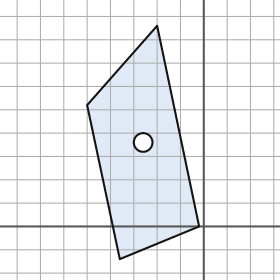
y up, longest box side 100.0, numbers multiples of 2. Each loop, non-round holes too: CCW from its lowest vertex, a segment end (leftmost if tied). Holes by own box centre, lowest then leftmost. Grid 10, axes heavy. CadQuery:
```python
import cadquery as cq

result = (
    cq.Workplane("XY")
    .moveTo(-36.0, -14.0)
    .lineTo(-2.0, 0.0)
    .lineTo(-20.0, 86.0)
    .lineTo(-50.0, 52.0)
    .close()
    .moveTo(-26.0, 36.0)
    .circle(4.0)
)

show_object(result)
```